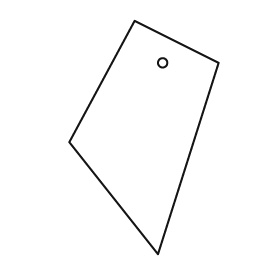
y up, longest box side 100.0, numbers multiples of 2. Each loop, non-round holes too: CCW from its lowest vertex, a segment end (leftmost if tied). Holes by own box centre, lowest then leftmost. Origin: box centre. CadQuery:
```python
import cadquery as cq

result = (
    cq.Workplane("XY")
    .moveTo(6.0, -50.0)
    .lineTo(32.0, 32.0)
    .lineTo(-4.0, 50.0)
    .lineTo(-32.0, -2.0)
    .close()
    .moveTo(8.0, 32.0)
    .circle(2.0)
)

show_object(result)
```